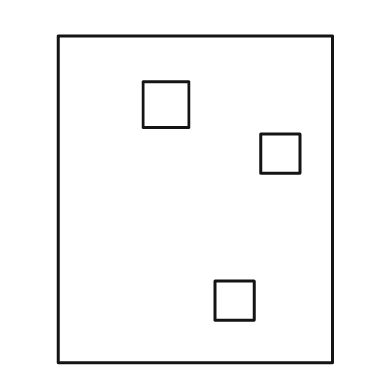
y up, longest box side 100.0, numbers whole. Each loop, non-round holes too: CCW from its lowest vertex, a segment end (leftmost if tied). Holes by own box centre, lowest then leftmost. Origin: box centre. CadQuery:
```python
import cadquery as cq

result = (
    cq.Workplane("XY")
    .moveTo(-42.0, -50.0)
    .lineTo(42.0, -50.0)
    .lineTo(42.0, 50.0)
    .lineTo(-42.0, 50.0)
    .close()
    .moveTo(6.0, -37.0)
    .lineTo(18.0, -37.0)
    .lineTo(18.0, -25.0)
    .lineTo(6.0, -25.0)
    .close()
    .moveTo(20.0, 8.0)
    .lineTo(32.0, 8.0)
    .lineTo(32.0, 20.0)
    .lineTo(20.0, 20.0)
    .close()
    .moveTo(-16.0, 22.0)
    .lineTo(-2.0, 22.0)
    .lineTo(-2.0, 36.0)
    .lineTo(-16.0, 36.0)
    .close()
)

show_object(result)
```